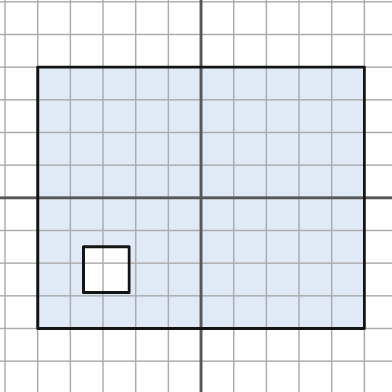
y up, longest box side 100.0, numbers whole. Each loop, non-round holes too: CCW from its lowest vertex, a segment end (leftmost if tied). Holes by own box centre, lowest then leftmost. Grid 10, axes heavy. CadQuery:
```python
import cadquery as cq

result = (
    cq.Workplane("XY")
    .moveTo(-50.0, -40.0)
    .lineTo(50.0, -40.0)
    .lineTo(50.0, 40.0)
    .lineTo(-50.0, 40.0)
    .close()
    .moveTo(-36.0, -29.0)
    .lineTo(-22.0, -29.0)
    .lineTo(-22.0, -15.0)
    .lineTo(-36.0, -15.0)
    .close()
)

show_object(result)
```